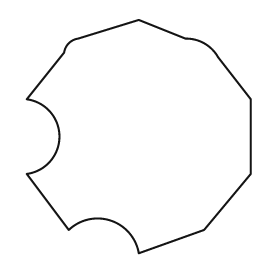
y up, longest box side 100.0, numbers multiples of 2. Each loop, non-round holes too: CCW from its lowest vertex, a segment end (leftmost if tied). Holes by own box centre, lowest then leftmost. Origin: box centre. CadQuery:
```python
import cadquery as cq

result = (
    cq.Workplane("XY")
    .moveTo(0.0, -50.0)
    .lineTo(28.0, -40.0)
    .lineTo(48.0, -16.0)
    .lineTo(48.0, 16.0)
    .lineTo(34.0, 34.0)
    .threePointArc((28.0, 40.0), (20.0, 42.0))
    .lineTo(0.0, 50.0)
    .lineTo(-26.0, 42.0)
    .threePointArc((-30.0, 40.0), (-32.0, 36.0))
    .lineTo(-48.0, 16.0)
    .threePointArc((-34.0, 0.0), (-48.0, -16.0))
    .lineTo(-30.0, -40.0)
    .threePointArc((-12.0, -36.0), (0.0, -50.0))
    .close()
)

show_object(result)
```